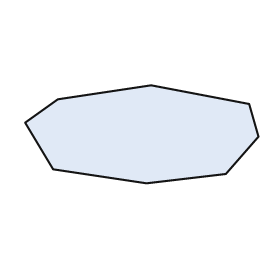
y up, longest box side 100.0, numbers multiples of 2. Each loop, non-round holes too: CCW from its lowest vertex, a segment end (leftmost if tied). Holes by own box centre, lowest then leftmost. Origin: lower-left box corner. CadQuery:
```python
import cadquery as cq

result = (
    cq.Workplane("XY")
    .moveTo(52.0, 0.0)
    .lineTo(86.0, 4.0)
    .lineTo(100.0, 20.0)
    .lineTo(96.0, 34.0)
    .lineTo(54.0, 42.0)
    .lineTo(14.0, 36.0)
    .lineTo(0.0, 26.0)
    .lineTo(12.0, 6.0)
    .close()
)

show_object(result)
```